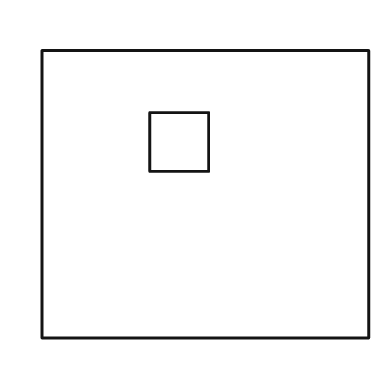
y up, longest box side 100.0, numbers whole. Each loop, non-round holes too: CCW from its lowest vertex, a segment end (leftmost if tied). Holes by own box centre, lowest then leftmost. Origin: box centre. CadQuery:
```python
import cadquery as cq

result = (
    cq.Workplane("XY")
    .moveTo(-50.0, -44.0)
    .lineTo(50.0, -44.0)
    .lineTo(50.0, 44.0)
    .lineTo(-50.0, 44.0)
    .close()
    .moveTo(-17.0, 7.0)
    .lineTo(1.0, 7.0)
    .lineTo(1.0, 25.0)
    .lineTo(-17.0, 25.0)
    .close()
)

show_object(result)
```